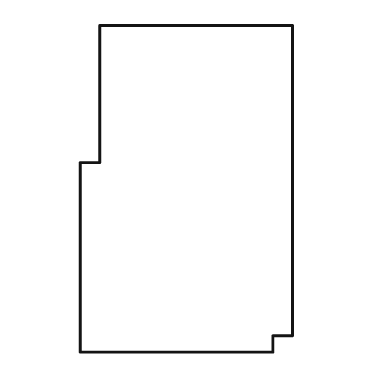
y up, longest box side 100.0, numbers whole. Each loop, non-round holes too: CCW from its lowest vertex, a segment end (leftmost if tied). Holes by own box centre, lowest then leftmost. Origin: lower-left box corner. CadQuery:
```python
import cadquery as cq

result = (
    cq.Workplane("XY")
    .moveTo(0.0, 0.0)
    .lineTo(59.0, 0.0)
    .lineTo(59.0, 5.0)
    .lineTo(65.0, 5.0)
    .lineTo(65.0, 100.0)
    .lineTo(6.0, 100.0)
    .lineTo(6.0, 58.0)
    .lineTo(0.0, 58.0)
    .close()
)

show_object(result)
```